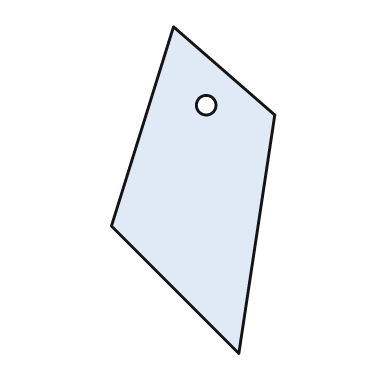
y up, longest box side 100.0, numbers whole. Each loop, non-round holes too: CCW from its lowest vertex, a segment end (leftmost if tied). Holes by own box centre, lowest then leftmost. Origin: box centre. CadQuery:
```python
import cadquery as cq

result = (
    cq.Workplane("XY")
    .moveTo(14.0, -50.0)
    .lineTo(25.0, 23.0)
    .lineTo(-6.0, 50.0)
    .lineTo(-25.0, -11.0)
    .close()
    .moveTo(4.0, 26.0)
    .circle(3.0)
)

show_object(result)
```